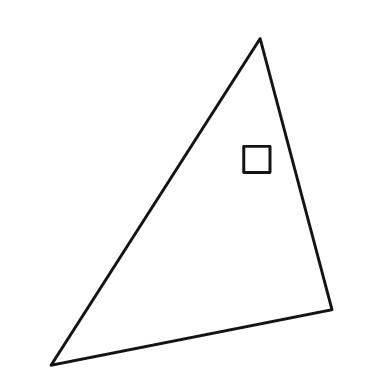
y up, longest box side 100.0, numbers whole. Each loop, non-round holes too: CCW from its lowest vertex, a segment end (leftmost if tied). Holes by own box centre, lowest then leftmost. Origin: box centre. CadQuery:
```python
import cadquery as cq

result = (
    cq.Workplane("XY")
    .moveTo(-43.0, -50.0)
    .lineTo(43.0, -33.0)
    .lineTo(21.0, 50.0)
    .close()
    .moveTo(16.0, 9.0)
    .lineTo(24.0, 9.0)
    .lineTo(24.0, 17.0)
    .lineTo(16.0, 17.0)
    .close()
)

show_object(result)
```